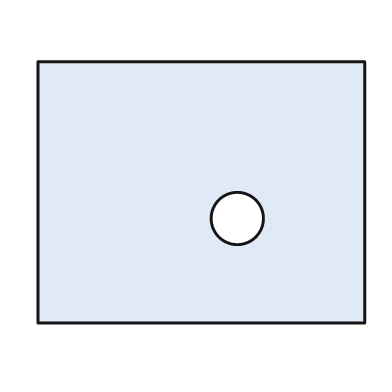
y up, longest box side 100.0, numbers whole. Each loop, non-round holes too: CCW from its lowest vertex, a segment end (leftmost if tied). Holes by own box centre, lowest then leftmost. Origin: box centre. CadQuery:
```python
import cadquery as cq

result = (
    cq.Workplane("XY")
    .moveTo(-50.0, -40.0)
    .lineTo(50.0, -40.0)
    .lineTo(50.0, 40.0)
    .lineTo(-50.0, 40.0)
    .close()
    .moveTo(11.0, -8.0)
    .circle(8.0)
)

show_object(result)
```